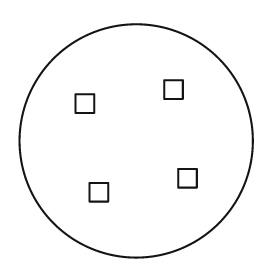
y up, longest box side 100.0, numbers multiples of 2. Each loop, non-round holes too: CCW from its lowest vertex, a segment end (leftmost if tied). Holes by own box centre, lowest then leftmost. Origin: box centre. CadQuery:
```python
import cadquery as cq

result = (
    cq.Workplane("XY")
    .moveTo(0.0, 0.0)
    .circle(50.0)
    .moveTo(-20.0, -26.0)
    .lineTo(-12.0, -26.0)
    .lineTo(-12.0, -18.0)
    .lineTo(-20.0, -18.0)
    .close()
    .moveTo(18.0, -20.0)
    .lineTo(26.0, -20.0)
    .lineTo(26.0, -12.0)
    .lineTo(18.0, -12.0)
    .close()
    .moveTo(-26.0, 12.0)
    .lineTo(-18.0, 12.0)
    .lineTo(-18.0, 20.0)
    .lineTo(-26.0, 20.0)
    .close()
    .moveTo(12.0, 18.0)
    .lineTo(20.0, 18.0)
    .lineTo(20.0, 26.0)
    .lineTo(12.0, 26.0)
    .close()
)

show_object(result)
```